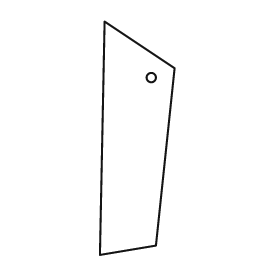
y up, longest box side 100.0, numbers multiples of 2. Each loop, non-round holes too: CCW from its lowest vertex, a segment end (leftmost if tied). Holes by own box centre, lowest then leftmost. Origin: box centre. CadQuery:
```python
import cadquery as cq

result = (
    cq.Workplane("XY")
    .moveTo(-16.0, -50.0)
    .lineTo(8.0, -46.0)
    .lineTo(16.0, 30.0)
    .lineTo(-14.0, 50.0)
    .close()
    .moveTo(6.0, 26.0)
    .circle(2.0)
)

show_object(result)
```